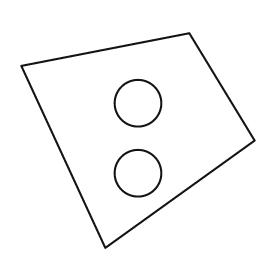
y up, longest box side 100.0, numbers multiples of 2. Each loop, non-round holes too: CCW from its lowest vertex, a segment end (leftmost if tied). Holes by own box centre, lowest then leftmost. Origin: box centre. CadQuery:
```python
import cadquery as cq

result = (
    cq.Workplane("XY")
    .moveTo(-14.0, -46.0)
    .lineTo(50.0, 0.0)
    .lineTo(22.0, 46.0)
    .lineTo(-50.0, 32.0)
    .close()
    .moveTo(0.0, -14.0)
    .circle(10.0)
    .moveTo(0.0, 16.0)
    .circle(10.0)
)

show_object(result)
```